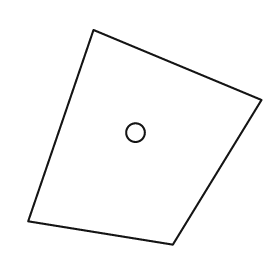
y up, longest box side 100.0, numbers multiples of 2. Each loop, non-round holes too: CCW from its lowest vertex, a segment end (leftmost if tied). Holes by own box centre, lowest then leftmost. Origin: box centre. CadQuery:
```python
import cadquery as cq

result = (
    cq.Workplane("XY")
    .moveTo(12.0, -46.0)
    .lineTo(50.0, 16.0)
    .lineTo(-22.0, 46.0)
    .lineTo(-50.0, -36.0)
    .close()
    .moveTo(-4.0, 2.0)
    .circle(4.0)
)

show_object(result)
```